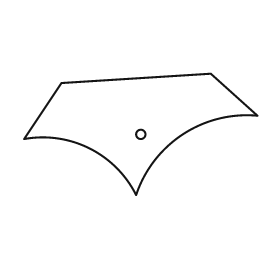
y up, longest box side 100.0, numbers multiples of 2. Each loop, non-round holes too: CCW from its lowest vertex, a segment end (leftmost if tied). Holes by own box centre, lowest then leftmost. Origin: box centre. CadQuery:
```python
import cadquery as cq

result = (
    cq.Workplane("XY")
    .moveTo(-2.0, -26.0)
    .threePointArc((18.0, 0.0), (50.0, 8.0))
    .lineTo(30.0, 26.0)
    .lineTo(-34.0, 22.0)
    .lineTo(-50.0, -2.0)
    .threePointArc((-22.0, -6.0), (-2.0, -26.0))
    .close()
    .moveTo(0.0, 0.0)
    .circle(2.0)
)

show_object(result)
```